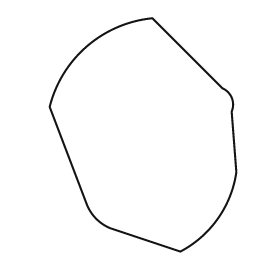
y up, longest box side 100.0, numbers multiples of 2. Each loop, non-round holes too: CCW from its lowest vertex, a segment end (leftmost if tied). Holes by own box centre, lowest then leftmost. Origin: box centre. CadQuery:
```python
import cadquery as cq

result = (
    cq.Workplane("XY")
    .moveTo(16.0, -50.0)
    .threePointArc((32.0, -36.0), (40.0, -16.0))
    .lineTo(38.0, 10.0)
    .threePointArc((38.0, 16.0), (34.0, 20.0))
    .lineTo(4.0, 50.0)
    .threePointArc((-24.0, 38.0), (-40.0, 12.0))
    .lineTo(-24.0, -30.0)
    .threePointArc((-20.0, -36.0), (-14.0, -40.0))
    .close()
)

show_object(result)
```